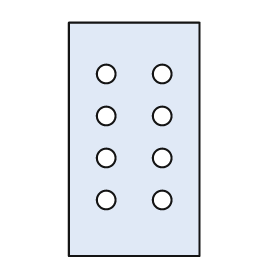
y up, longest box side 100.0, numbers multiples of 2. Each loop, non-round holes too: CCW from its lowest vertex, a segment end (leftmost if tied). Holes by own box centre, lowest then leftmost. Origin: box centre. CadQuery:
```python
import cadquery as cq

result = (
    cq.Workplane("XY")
    .moveTo(-28.0, -50.0)
    .lineTo(28.0, -50.0)
    .lineTo(28.0, 50.0)
    .lineTo(-28.0, 50.0)
    .close()
    .moveTo(-12.0, -26.0)
    .circle(4.0)
    .moveTo(12.0, -26.0)
    .circle(4.0)
    .moveTo(-12.0, -8.0)
    .circle(4.0)
    .moveTo(12.0, -8.0)
    .circle(4.0)
    .moveTo(-12.0, 10.0)
    .circle(4.0)
    .moveTo(12.0, 10.0)
    .circle(4.0)
    .moveTo(-12.0, 28.0)
    .circle(4.0)
    .moveTo(12.0, 28.0)
    .circle(4.0)
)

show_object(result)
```